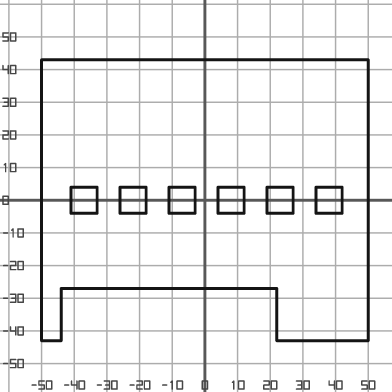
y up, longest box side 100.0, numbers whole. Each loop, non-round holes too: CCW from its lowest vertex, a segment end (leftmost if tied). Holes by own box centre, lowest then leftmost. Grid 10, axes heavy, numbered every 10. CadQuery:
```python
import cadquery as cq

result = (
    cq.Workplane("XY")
    .moveTo(-50.0, -43.0)
    .lineTo(-44.0, -43.0)
    .lineTo(-44.0, -27.0)
    .lineTo(22.0, -27.0)
    .lineTo(22.0, -43.0)
    .lineTo(50.0, -43.0)
    .lineTo(50.0, 43.0)
    .lineTo(-50.0, 43.0)
    .close()
    .moveTo(-41.0, -4.0)
    .lineTo(-33.0, -4.0)
    .lineTo(-33.0, 4.0)
    .lineTo(-41.0, 4.0)
    .close()
    .moveTo(-26.0, -4.0)
    .lineTo(-18.0, -4.0)
    .lineTo(-18.0, 4.0)
    .lineTo(-26.0, 4.0)
    .close()
    .moveTo(-11.0, -4.0)
    .lineTo(-3.0, -4.0)
    .lineTo(-3.0, 4.0)
    .lineTo(-11.0, 4.0)
    .close()
    .moveTo(4.0, -4.0)
    .lineTo(12.0, -4.0)
    .lineTo(12.0, 4.0)
    .lineTo(4.0, 4.0)
    .close()
    .moveTo(19.0, -4.0)
    .lineTo(27.0, -4.0)
    .lineTo(27.0, 4.0)
    .lineTo(19.0, 4.0)
    .close()
    .moveTo(34.0, -4.0)
    .lineTo(42.0, -4.0)
    .lineTo(42.0, 4.0)
    .lineTo(34.0, 4.0)
    .close()
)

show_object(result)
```